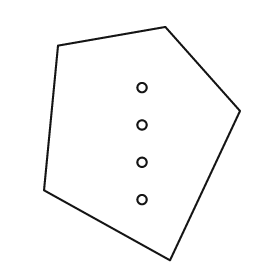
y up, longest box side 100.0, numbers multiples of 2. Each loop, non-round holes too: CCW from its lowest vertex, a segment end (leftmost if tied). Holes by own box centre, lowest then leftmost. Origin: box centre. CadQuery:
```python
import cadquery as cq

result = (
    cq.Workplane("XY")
    .moveTo(12.0, -50.0)
    .lineTo(42.0, 14.0)
    .lineTo(10.0, 50.0)
    .lineTo(-36.0, 42.0)
    .lineTo(-42.0, -20.0)
    .close()
    .moveTo(0.0, -24.0)
    .circle(2.0)
    .moveTo(0.0, -8.0)
    .circle(2.0)
    .moveTo(0.0, 8.0)
    .circle(2.0)
    .moveTo(0.0, 24.0)
    .circle(2.0)
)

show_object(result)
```